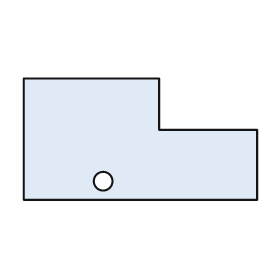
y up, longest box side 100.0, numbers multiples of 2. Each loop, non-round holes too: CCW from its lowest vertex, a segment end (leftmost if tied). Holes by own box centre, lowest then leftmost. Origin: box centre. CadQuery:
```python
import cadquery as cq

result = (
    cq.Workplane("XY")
    .moveTo(-50.0, -26.0)
    .lineTo(50.0, -26.0)
    .lineTo(50.0, 4.0)
    .lineTo(8.0, 4.0)
    .lineTo(8.0, 26.0)
    .lineTo(-50.0, 26.0)
    .close()
    .moveTo(-16.0, -18.0)
    .circle(4.0)
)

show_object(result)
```